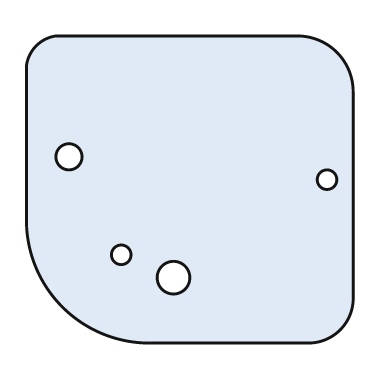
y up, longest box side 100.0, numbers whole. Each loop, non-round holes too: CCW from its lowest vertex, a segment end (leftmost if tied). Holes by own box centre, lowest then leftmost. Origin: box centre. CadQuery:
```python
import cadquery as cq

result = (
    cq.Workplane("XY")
    .moveTo(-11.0, -47.0)
    .lineTo(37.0, -47.0)
    .threePointArc((46.0, -43.0), (50.0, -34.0))
    .lineTo(50.0, 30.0)
    .threePointArc((45.0, 42.0), (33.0, 47.0))
    .lineTo(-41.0, 47.0)
    .threePointArc((-47.0, 44.0), (-50.0, 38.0))
    .lineTo(-50.0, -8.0)
    .threePointArc((-39.0, -36.0), (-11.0, -47.0))
    .close()
    .moveTo(-5.0, -27.0)
    .circle(5.0)
    .moveTo(-21.0, -20.0)
    .circle(3.0)
    .moveTo(42.0, 3.0)
    .circle(3.0)
    .moveTo(-37.0, 10.0)
    .circle(4.0)
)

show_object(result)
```